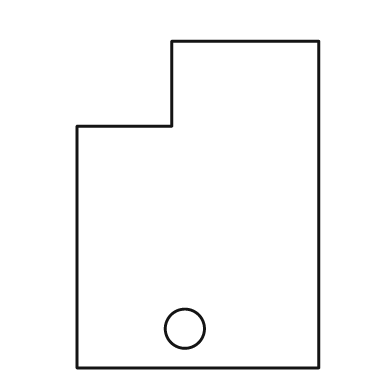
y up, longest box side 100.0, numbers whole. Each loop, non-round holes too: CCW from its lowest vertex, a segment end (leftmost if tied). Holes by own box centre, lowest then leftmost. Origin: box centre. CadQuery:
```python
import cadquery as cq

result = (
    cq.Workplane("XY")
    .moveTo(-37.0, -50.0)
    .lineTo(37.0, -50.0)
    .lineTo(37.0, 50.0)
    .lineTo(-8.0, 50.0)
    .lineTo(-8.0, 24.0)
    .lineTo(-37.0, 24.0)
    .close()
    .moveTo(-4.0, -38.0)
    .circle(6.0)
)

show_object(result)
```